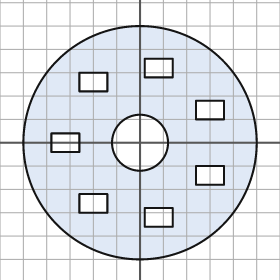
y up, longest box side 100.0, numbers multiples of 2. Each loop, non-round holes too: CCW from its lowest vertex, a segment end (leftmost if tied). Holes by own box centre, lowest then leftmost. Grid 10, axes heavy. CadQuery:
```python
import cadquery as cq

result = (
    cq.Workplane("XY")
    .moveTo(0.0, 0.0)
    .circle(50.0)
    .moveTo(2.0, -36.0)
    .lineTo(14.0, -36.0)
    .lineTo(14.0, -28.0)
    .lineTo(2.0, -28.0)
    .close()
    .moveTo(-26.0, -30.0)
    .lineTo(-14.0, -30.0)
    .lineTo(-14.0, -22.0)
    .lineTo(-26.0, -22.0)
    .close()
    .moveTo(24.0, -18.0)
    .lineTo(36.0, -18.0)
    .lineTo(36.0, -10.0)
    .lineTo(24.0, -10.0)
    .close()
    .moveTo(-38.0, -4.0)
    .lineTo(-26.0, -4.0)
    .lineTo(-26.0, 4.0)
    .lineTo(-38.0, 4.0)
    .close()
    .moveTo(0.0, 0.0)
    .circle(12.0)
    .moveTo(24.0, 10.0)
    .lineTo(36.0, 10.0)
    .lineTo(36.0, 18.0)
    .lineTo(24.0, 18.0)
    .close()
    .moveTo(-26.0, 22.0)
    .lineTo(-14.0, 22.0)
    .lineTo(-14.0, 30.0)
    .lineTo(-26.0, 30.0)
    .close()
    .moveTo(2.0, 28.0)
    .lineTo(14.0, 28.0)
    .lineTo(14.0, 36.0)
    .lineTo(2.0, 36.0)
    .close()
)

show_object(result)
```